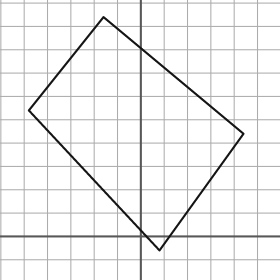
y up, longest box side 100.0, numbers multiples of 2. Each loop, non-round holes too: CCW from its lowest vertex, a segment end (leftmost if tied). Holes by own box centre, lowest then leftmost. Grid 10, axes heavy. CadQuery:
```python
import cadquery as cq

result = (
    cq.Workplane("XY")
    .moveTo(8.0, -6.0)
    .lineTo(44.0, 44.0)
    .lineTo(-16.0, 94.0)
    .lineTo(-48.0, 54.0)
    .close()
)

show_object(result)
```